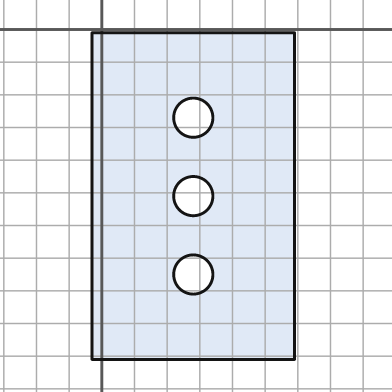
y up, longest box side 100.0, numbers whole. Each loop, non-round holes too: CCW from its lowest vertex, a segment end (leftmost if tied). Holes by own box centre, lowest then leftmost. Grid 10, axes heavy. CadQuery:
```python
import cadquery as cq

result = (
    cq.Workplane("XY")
    .moveTo(-3.0, -101.0)
    .lineTo(59.0, -101.0)
    .lineTo(59.0, -1.0)
    .lineTo(-3.0, -1.0)
    .close()
    .moveTo(28.0, -75.0)
    .circle(6.0)
    .moveTo(28.0, -51.0)
    .circle(6.0)
    .moveTo(28.0, -27.0)
    .circle(6.0)
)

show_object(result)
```